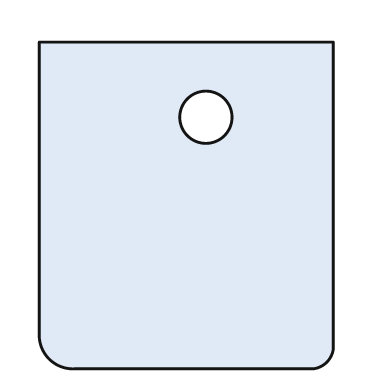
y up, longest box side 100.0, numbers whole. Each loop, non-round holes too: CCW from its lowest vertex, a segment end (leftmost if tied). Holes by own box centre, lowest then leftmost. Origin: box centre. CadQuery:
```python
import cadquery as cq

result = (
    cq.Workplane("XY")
    .moveTo(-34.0, -50.0)
    .lineTo(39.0, -50.0)
    .threePointArc((43.0, -48.0), (45.0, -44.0))
    .lineTo(45.0, 50.0)
    .lineTo(-45.0, 50.0)
    .lineTo(-45.0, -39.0)
    .threePointArc((-42.0, -47.0), (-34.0, -50.0))
    .close()
    .moveTo(6.0, 27.0)
    .circle(8.0)
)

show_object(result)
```